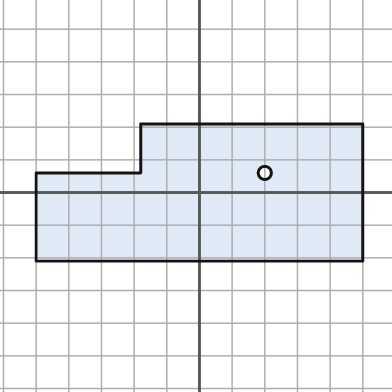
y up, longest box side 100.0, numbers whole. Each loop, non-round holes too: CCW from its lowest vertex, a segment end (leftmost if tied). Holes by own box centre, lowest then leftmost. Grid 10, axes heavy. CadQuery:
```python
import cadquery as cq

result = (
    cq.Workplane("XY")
    .moveTo(-50.0, -21.0)
    .lineTo(50.0, -21.0)
    .lineTo(50.0, 21.0)
    .lineTo(-18.0, 21.0)
    .lineTo(-18.0, 6.0)
    .lineTo(-50.0, 6.0)
    .close()
    .moveTo(20.0, 6.0)
    .circle(2.0)
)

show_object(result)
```